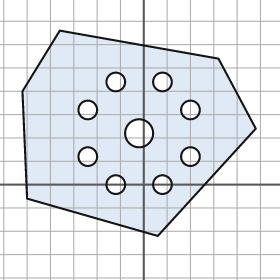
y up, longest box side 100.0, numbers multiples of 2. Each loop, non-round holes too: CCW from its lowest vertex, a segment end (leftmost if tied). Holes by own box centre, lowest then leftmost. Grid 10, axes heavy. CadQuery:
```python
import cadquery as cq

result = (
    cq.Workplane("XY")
    .moveTo(6.0, -22.0)
    .lineTo(48.0, 24.0)
    .lineTo(32.0, 54.0)
    .lineTo(-36.0, 66.0)
    .lineTo(-52.0, 40.0)
    .lineTo(-50.0, -6.0)
    .close()
    .moveTo(-12.0, 0.0)
    .circle(4.0)
    .moveTo(8.0, 0.0)
    .circle(4.0)
    .moveTo(-24.0, 12.0)
    .circle(4.0)
    .moveTo(20.0, 12.0)
    .circle(4.0)
    .moveTo(-2.0, 22.0)
    .circle(6.0)
    .moveTo(-24.0, 32.0)
    .circle(4.0)
    .moveTo(20.0, 32.0)
    .circle(4.0)
    .moveTo(-12.0, 44.0)
    .circle(4.0)
    .moveTo(8.0, 44.0)
    .circle(4.0)
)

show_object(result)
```